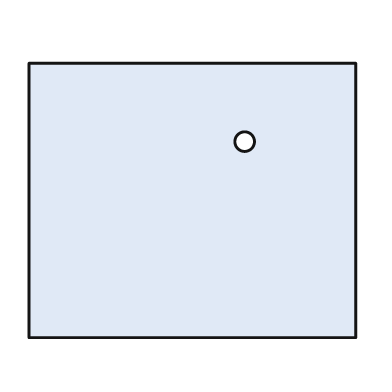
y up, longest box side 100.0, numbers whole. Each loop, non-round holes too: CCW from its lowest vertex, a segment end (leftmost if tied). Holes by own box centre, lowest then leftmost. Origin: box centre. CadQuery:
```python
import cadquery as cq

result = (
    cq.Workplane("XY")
    .moveTo(-50.0, -42.0)
    .lineTo(50.0, -42.0)
    .lineTo(50.0, 42.0)
    .lineTo(-50.0, 42.0)
    .close()
    .moveTo(16.0, 18.0)
    .circle(3.0)
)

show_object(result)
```